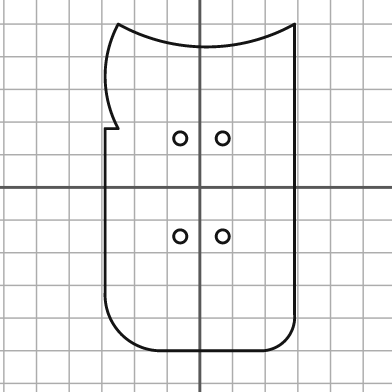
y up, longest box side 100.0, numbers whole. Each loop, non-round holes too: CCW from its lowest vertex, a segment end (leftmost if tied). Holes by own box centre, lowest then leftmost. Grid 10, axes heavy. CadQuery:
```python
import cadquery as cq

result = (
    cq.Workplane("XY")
    .moveTo(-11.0, -50.0)
    .lineTo(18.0, -50.0)
    .threePointArc((26.0, -47.0), (29.0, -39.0))
    .lineTo(29.0, 50.0)
    .threePointArc((2.0, 43.0), (-25.0, 50.0))
    .threePointArc((-29.0, 34.0), (-25.0, 18.0))
    .lineTo(-29.0, 18.0)
    .lineTo(-29.0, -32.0)
    .threePointArc((-24.0, -45.0), (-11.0, -50.0))
    .close()
    .moveTo(-6.0, -15.0)
    .circle(2.0)
    .moveTo(7.0, -15.0)
    .circle(2.0)
    .moveTo(-6.0, 15.0)
    .circle(2.0)
    .moveTo(7.0, 15.0)
    .circle(2.0)
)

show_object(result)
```